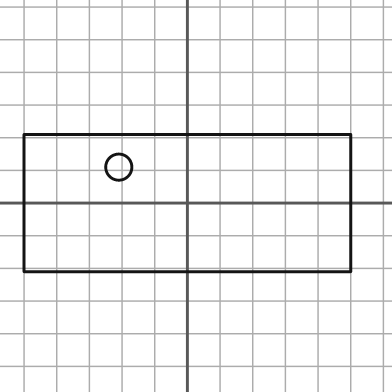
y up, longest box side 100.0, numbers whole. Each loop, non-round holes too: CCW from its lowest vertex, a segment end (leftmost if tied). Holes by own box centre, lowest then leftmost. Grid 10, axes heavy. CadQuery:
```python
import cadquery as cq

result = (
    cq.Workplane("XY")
    .moveTo(-50.0, -21.0)
    .lineTo(50.0, -21.0)
    .lineTo(50.0, 21.0)
    .lineTo(-50.0, 21.0)
    .close()
    .moveTo(-21.0, 11.0)
    .circle(4.0)
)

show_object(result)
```